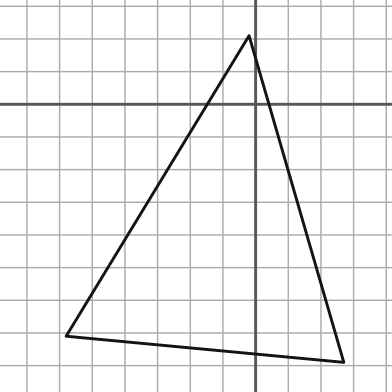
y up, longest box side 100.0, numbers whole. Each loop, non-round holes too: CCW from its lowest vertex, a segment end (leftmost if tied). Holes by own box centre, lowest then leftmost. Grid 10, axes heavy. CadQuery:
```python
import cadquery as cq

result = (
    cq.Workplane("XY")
    .moveTo(27.0, -79.0)
    .lineTo(-2.0, 21.0)
    .lineTo(-58.0, -71.0)
    .close()
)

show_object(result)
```